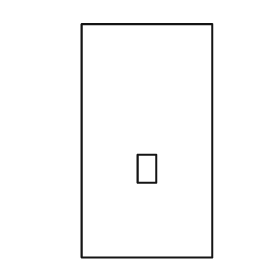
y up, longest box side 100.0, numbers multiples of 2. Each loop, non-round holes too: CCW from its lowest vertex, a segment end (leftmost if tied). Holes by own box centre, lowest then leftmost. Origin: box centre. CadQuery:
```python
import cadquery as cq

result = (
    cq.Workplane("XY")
    .moveTo(-28.0, -50.0)
    .lineTo(28.0, -50.0)
    .lineTo(28.0, 50.0)
    .lineTo(-28.0, 50.0)
    .close()
    .moveTo(-4.0, -18.0)
    .lineTo(4.0, -18.0)
    .lineTo(4.0, -6.0)
    .lineTo(-4.0, -6.0)
    .close()
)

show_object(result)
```